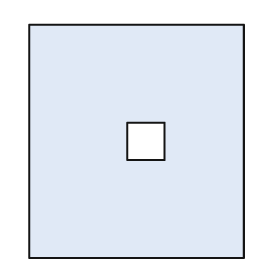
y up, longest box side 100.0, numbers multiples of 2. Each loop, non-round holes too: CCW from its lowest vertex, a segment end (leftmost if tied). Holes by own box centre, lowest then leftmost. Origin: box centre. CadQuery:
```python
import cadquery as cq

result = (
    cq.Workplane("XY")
    .moveTo(-46.0, -50.0)
    .lineTo(46.0, -50.0)
    .lineTo(46.0, 50.0)
    .lineTo(-46.0, 50.0)
    .close()
    .moveTo(-4.0, -8.0)
    .lineTo(12.0, -8.0)
    .lineTo(12.0, 8.0)
    .lineTo(-4.0, 8.0)
    .close()
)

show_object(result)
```